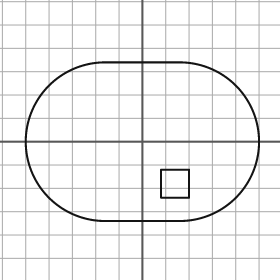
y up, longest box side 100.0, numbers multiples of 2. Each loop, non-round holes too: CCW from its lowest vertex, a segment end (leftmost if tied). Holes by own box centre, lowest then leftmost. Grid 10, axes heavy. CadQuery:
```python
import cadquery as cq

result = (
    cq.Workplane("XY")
    .moveTo(-16.0, -34.0)
    .lineTo(16.0, -34.0)
    .threePointArc((50.0, 0.0), (16.0, 34.0))
    .lineTo(-16.0, 34.0)
    .threePointArc((-50.0, 0.0), (-16.0, -34.0))
    .close()
    .moveTo(8.0, -24.0)
    .lineTo(20.0, -24.0)
    .lineTo(20.0, -12.0)
    .lineTo(8.0, -12.0)
    .close()
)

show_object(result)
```